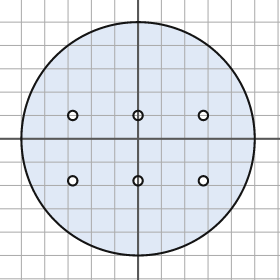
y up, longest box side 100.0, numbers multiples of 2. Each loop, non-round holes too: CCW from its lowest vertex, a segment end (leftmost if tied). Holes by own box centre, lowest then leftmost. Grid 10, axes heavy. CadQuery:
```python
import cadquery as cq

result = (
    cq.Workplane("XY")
    .moveTo(0.0, 0.0)
    .circle(50.0)
    .moveTo(-28.0, -18.0)
    .circle(2.0)
    .moveTo(0.0, -18.0)
    .circle(2.0)
    .moveTo(28.0, -18.0)
    .circle(2.0)
    .moveTo(-28.0, 10.0)
    .circle(2.0)
    .moveTo(0.0, 10.0)
    .circle(2.0)
    .moveTo(28.0, 10.0)
    .circle(2.0)
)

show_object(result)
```